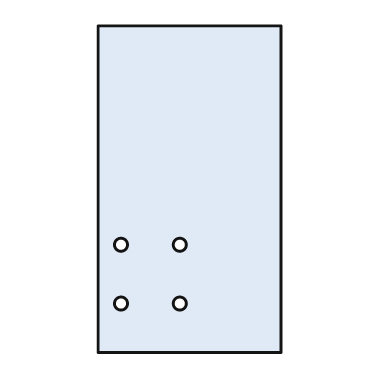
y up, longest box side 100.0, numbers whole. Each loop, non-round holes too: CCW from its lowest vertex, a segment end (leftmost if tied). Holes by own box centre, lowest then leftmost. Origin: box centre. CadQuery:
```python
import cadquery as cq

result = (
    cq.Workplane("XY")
    .moveTo(-28.0, -50.0)
    .lineTo(28.0, -50.0)
    .lineTo(28.0, 50.0)
    .lineTo(-28.0, 50.0)
    .close()
    .moveTo(-21.0, -35.0)
    .circle(2.0)
    .moveTo(-3.0, -35.0)
    .circle(2.0)
    .moveTo(-21.0, -17.0)
    .circle(2.0)
    .moveTo(-3.0, -17.0)
    .circle(2.0)
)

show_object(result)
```